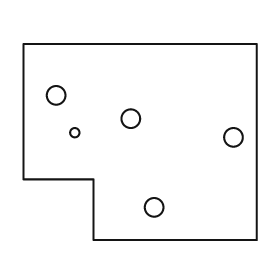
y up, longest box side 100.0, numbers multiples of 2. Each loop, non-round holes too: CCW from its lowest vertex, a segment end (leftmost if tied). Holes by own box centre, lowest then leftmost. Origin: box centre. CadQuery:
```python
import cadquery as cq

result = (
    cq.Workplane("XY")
    .moveTo(-20.0, -42.0)
    .lineTo(50.0, -42.0)
    .lineTo(50.0, 42.0)
    .lineTo(-50.0, 42.0)
    .lineTo(-50.0, -16.0)
    .lineTo(-20.0, -16.0)
    .close()
    .moveTo(6.0, -28.0)
    .circle(4.0)
    .moveTo(40.0, 2.0)
    .circle(4.0)
    .moveTo(-28.0, 4.0)
    .circle(2.0)
    .moveTo(-4.0, 10.0)
    .circle(4.0)
    .moveTo(-36.0, 20.0)
    .circle(4.0)
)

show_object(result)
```